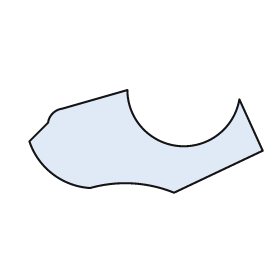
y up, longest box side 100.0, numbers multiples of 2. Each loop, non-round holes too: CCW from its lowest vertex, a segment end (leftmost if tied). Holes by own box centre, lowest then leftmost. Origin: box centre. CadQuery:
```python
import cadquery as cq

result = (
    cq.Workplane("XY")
    .moveTo(12.0, -22.0)
    .lineTo(50.0, -4.0)
    .lineTo(40.0, 18.0)
    .threePointArc((14.0, -2.0), (-8.0, 22.0))
    .lineTo(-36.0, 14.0)
    .threePointArc((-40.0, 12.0), (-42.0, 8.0))
    .lineTo(-50.0, 0.0)
    .threePointArc((-40.0, -14.0), (-24.0, -20.0))
    .threePointArc((-6.0, -18.0), (12.0, -22.0))
    .close()
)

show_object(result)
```